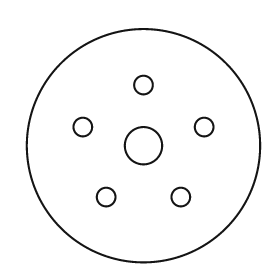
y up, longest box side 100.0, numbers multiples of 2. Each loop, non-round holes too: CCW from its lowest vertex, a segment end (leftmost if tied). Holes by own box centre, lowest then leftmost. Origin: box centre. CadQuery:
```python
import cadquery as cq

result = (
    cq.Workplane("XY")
    .moveTo(0.0, 0.0)
    .circle(50.0)
    .moveTo(-16.0, -22.0)
    .circle(4.0)
    .moveTo(16.0, -22.0)
    .circle(4.0)
    .moveTo(0.0, 0.0)
    .circle(8.0)
    .moveTo(-26.0, 8.0)
    .circle(4.0)
    .moveTo(26.0, 8.0)
    .circle(4.0)
    .moveTo(0.0, 26.0)
    .circle(4.0)
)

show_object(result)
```